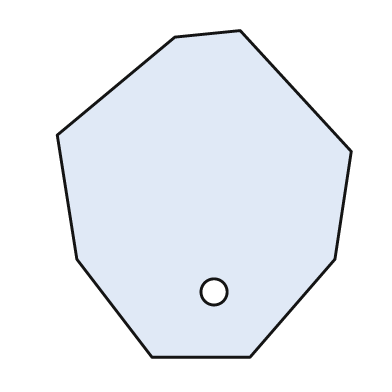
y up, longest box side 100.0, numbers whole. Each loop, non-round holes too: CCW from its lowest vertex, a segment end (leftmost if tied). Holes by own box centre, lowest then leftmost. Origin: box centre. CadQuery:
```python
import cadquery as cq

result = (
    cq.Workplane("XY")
    .moveTo(-16.0, -50.0)
    .lineTo(14.0, -50.0)
    .lineTo(40.0, -20.0)
    .lineTo(45.0, 13.0)
    .lineTo(11.0, 50.0)
    .lineTo(-9.0, 48.0)
    .lineTo(-45.0, 18.0)
    .lineTo(-39.0, -20.0)
    .close()
    .moveTo(3.0, -30.0)
    .circle(4.0)
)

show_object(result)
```